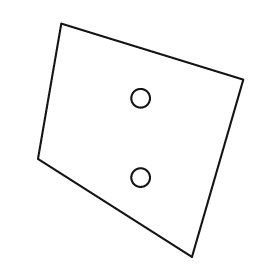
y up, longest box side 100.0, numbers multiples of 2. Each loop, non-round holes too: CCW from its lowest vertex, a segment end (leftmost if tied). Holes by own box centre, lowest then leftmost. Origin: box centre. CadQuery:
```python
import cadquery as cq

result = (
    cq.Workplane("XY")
    .moveTo(22.0, -50.0)
    .lineTo(44.0, 26.0)
    .lineTo(-34.0, 50.0)
    .lineTo(-44.0, -8.0)
    .close()
    .moveTo(0.0, -16.0)
    .circle(4.0)
    .moveTo(0.0, 18.0)
    .circle(4.0)
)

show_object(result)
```